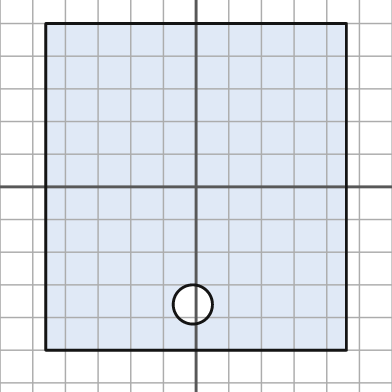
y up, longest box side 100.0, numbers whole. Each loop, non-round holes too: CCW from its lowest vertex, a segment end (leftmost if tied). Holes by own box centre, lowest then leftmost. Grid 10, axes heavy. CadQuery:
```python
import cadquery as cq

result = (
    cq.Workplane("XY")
    .moveTo(-46.0, -50.0)
    .lineTo(46.0, -50.0)
    .lineTo(46.0, 50.0)
    .lineTo(-46.0, 50.0)
    .close()
    .moveTo(-1.0, -36.0)
    .circle(6.0)
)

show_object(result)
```